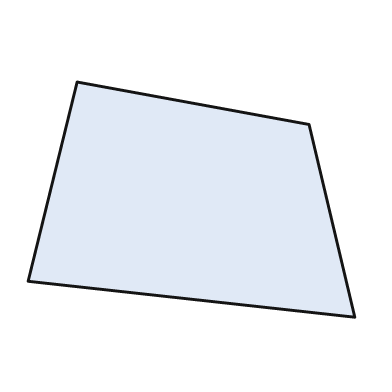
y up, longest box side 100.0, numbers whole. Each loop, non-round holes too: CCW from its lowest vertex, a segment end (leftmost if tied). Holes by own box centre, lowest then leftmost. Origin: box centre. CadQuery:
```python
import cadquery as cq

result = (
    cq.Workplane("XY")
    .moveTo(50.0, -36.0)
    .lineTo(36.0, 23.0)
    .lineTo(-35.0, 36.0)
    .lineTo(-50.0, -25.0)
    .close()
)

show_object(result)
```